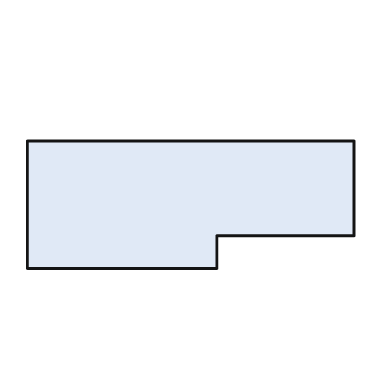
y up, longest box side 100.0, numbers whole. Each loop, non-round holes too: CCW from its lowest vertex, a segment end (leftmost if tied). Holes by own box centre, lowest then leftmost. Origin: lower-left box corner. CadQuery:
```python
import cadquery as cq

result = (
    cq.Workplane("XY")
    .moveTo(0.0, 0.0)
    .lineTo(58.0, 0.0)
    .lineTo(58.0, 10.0)
    .lineTo(100.0, 10.0)
    .lineTo(100.0, 39.0)
    .lineTo(0.0, 39.0)
    .close()
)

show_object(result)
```